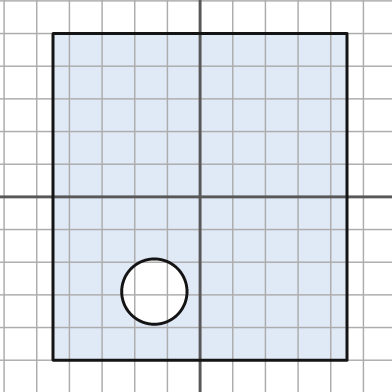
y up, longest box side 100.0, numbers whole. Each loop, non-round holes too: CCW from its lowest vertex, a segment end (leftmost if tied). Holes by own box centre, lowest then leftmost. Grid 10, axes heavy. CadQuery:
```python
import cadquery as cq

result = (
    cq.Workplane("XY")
    .moveTo(-45.0, -50.0)
    .lineTo(45.0, -50.0)
    .lineTo(45.0, 50.0)
    .lineTo(-45.0, 50.0)
    .close()
    .moveTo(-14.0, -29.0)
    .circle(10.0)
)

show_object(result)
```